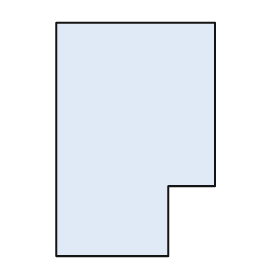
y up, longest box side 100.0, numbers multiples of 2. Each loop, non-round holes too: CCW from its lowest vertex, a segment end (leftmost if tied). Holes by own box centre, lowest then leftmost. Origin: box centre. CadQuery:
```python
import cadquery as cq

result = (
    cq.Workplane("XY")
    .moveTo(-34.0, -50.0)
    .lineTo(14.0, -50.0)
    .lineTo(14.0, -20.0)
    .lineTo(34.0, -20.0)
    .lineTo(34.0, 50.0)
    .lineTo(-34.0, 50.0)
    .close()
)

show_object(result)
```